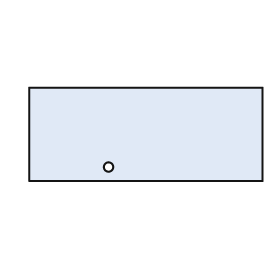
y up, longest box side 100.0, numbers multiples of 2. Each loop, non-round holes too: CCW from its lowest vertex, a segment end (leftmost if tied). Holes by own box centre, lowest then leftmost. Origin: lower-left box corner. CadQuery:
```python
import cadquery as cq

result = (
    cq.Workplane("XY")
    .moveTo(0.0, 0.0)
    .lineTo(100.0, 0.0)
    .lineTo(100.0, 40.0)
    .lineTo(0.0, 40.0)
    .close()
    .moveTo(34.0, 6.0)
    .circle(2.0)
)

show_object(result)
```